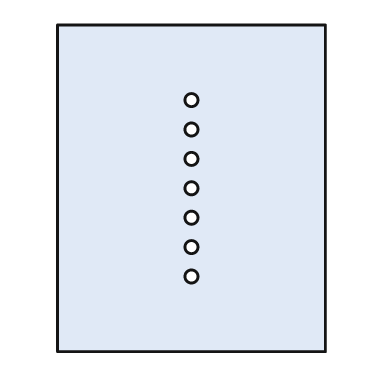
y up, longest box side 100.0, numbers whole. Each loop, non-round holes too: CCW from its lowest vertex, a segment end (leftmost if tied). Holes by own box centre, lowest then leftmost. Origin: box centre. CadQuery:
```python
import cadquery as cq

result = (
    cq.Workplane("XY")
    .moveTo(-41.0, -50.0)
    .lineTo(41.0, -50.0)
    .lineTo(41.0, 50.0)
    .lineTo(-41.0, 50.0)
    .close()
    .moveTo(0.0, -27.0)
    .circle(2.0)
    .moveTo(0.0, -18.0)
    .circle(2.0)
    .moveTo(0.0, -9.0)
    .circle(2.0)
    .moveTo(0.0, 0.0)
    .circle(2.0)
    .moveTo(0.0, 9.0)
    .circle(2.0)
    .moveTo(0.0, 18.0)
    .circle(2.0)
    .moveTo(0.0, 27.0)
    .circle(2.0)
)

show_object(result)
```